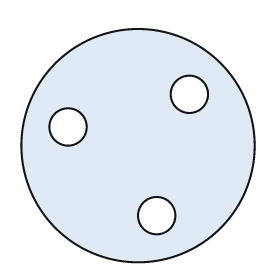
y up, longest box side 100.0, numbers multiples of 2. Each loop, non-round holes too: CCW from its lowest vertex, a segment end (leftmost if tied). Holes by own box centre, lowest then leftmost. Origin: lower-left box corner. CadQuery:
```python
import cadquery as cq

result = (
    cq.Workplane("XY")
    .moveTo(50.0, 50.0)
    .circle(50.0)
    .moveTo(58.0, 20.0)
    .circle(8.0)
    .moveTo(20.0, 58.0)
    .circle(8.0)
    .moveTo(72.0, 72.0)
    .circle(8.0)
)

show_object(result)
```